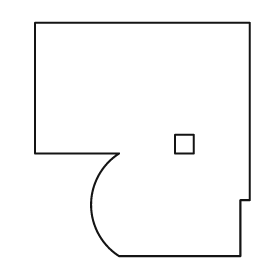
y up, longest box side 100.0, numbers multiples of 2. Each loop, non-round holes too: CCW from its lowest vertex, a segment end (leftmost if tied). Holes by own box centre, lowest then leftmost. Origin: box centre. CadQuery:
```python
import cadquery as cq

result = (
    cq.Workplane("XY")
    .moveTo(-10.0, -50.0)
    .lineTo(42.0, -50.0)
    .lineTo(42.0, -26.0)
    .lineTo(46.0, -26.0)
    .lineTo(46.0, 50.0)
    .lineTo(-46.0, 50.0)
    .lineTo(-46.0, -6.0)
    .lineTo(-10.0, -6.0)
    .threePointArc((-22.0, -28.0), (-10.0, -50.0))
    .close()
    .moveTo(14.0, -6.0)
    .lineTo(22.0, -6.0)
    .lineTo(22.0, 2.0)
    .lineTo(14.0, 2.0)
    .close()
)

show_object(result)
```